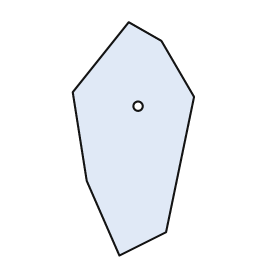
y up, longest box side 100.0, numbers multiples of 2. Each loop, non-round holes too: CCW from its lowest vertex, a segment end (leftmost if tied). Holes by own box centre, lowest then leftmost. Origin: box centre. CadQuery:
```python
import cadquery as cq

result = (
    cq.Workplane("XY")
    .moveTo(-6.0, -50.0)
    .lineTo(14.0, -40.0)
    .lineTo(26.0, 18.0)
    .lineTo(12.0, 42.0)
    .lineTo(-2.0, 50.0)
    .lineTo(-26.0, 20.0)
    .lineTo(-20.0, -18.0)
    .close()
    .moveTo(2.0, 14.0)
    .circle(2.0)
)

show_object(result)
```